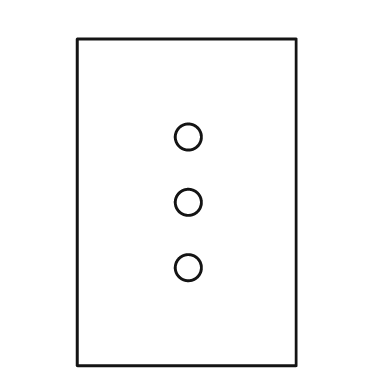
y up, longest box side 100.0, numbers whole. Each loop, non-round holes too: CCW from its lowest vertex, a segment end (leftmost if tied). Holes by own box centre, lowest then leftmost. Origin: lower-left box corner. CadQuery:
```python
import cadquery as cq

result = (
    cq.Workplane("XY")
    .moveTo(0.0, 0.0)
    .lineTo(67.0, 0.0)
    .lineTo(67.0, 100.0)
    .lineTo(0.0, 100.0)
    .close()
    .moveTo(34.0, 30.0)
    .circle(4.0)
    .moveTo(34.0, 50.0)
    .circle(4.0)
    .moveTo(34.0, 70.0)
    .circle(4.0)
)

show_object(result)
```